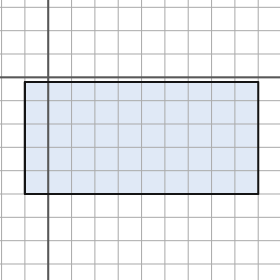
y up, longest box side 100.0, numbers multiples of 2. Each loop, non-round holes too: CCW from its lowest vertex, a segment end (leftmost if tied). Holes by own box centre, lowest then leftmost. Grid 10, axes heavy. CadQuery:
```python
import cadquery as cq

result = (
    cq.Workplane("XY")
    .moveTo(-10.0, -50.0)
    .lineTo(90.0, -50.0)
    .lineTo(90.0, -2.0)
    .lineTo(-10.0, -2.0)
    .close()
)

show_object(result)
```